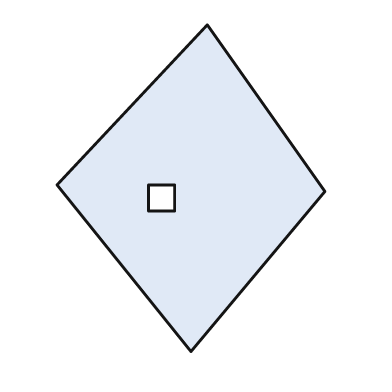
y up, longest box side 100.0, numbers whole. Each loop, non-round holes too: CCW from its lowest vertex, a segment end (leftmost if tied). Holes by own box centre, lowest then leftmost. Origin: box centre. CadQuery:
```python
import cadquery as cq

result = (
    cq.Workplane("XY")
    .moveTo(0.0, -50.0)
    .lineTo(41.0, -1.0)
    .lineTo(5.0, 50.0)
    .lineTo(-41.0, 1.0)
    .close()
    .moveTo(-13.0, -7.0)
    .lineTo(-5.0, -7.0)
    .lineTo(-5.0, 1.0)
    .lineTo(-13.0, 1.0)
    .close()
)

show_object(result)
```